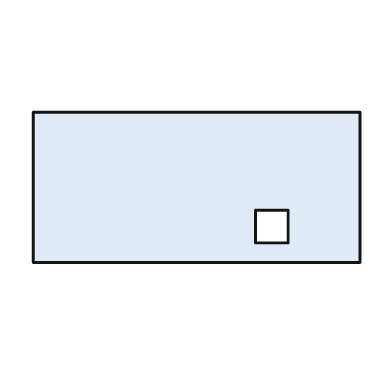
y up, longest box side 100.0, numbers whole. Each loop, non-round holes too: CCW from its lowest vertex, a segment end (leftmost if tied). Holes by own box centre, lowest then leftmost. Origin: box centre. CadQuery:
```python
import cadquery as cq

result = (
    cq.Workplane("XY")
    .moveTo(-50.0, -23.0)
    .lineTo(50.0, -23.0)
    .lineTo(50.0, 23.0)
    .lineTo(-50.0, 23.0)
    .close()
    .moveTo(18.0, -17.0)
    .lineTo(28.0, -17.0)
    .lineTo(28.0, -7.0)
    .lineTo(18.0, -7.0)
    .close()
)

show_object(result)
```